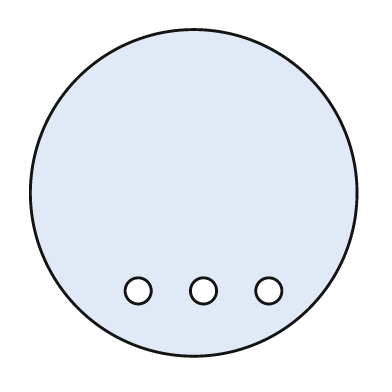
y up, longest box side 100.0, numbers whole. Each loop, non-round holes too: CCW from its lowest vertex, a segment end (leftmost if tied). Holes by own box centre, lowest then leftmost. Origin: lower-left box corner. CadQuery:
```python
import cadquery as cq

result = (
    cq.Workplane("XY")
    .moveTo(50.0, 50.0)
    .circle(50.0)
    .moveTo(33.0, 20.0)
    .circle(4.0)
    .moveTo(53.0, 20.0)
    .circle(4.0)
    .moveTo(73.0, 20.0)
    .circle(4.0)
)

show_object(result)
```